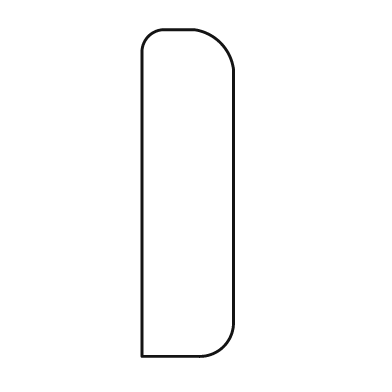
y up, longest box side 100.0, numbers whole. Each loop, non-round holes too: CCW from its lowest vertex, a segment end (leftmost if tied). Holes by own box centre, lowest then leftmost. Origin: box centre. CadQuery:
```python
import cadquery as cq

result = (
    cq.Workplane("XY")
    .moveTo(-14.0, -50.0)
    .lineTo(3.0, -50.0)
    .threePointArc((11.0, -47.0), (14.0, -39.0))
    .lineTo(14.0, 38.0)
    .threePointArc((10.0, 46.0), (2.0, 50.0))
    .lineTo(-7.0, 50.0)
    .threePointArc((-12.0, 48.0), (-14.0, 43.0))
    .close()
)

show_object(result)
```